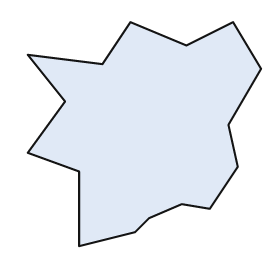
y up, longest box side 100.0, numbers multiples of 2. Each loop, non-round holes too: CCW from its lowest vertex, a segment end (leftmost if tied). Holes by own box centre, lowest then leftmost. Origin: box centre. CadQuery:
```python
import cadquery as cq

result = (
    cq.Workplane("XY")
    .moveTo(-28.0, -48.0)
    .lineTo(-4.0, -42.0)
    .lineTo(2.0, -36.0)
    .lineTo(16.0, -30.0)
    .lineTo(28.0, -32.0)
    .lineTo(40.0, -14.0)
    .lineTo(36.0, 4.0)
    .lineTo(50.0, 28.0)
    .lineTo(38.0, 48.0)
    .lineTo(18.0, 38.0)
    .lineTo(-6.0, 48.0)
    .lineTo(-18.0, 30.0)
    .lineTo(-50.0, 34.0)
    .lineTo(-34.0, 14.0)
    .lineTo(-50.0, -8.0)
    .lineTo(-28.0, -16.0)
    .close()
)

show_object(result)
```